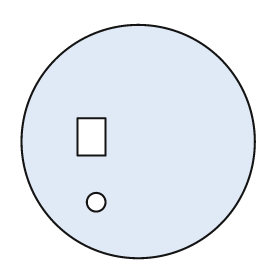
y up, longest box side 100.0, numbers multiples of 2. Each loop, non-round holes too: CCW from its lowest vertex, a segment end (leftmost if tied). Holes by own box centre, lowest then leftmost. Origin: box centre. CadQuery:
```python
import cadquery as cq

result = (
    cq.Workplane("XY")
    .moveTo(0.0, 0.0)
    .circle(50.0)
    .moveTo(-18.0, -26.0)
    .circle(4.0)
    .moveTo(-26.0, -6.0)
    .lineTo(-14.0, -6.0)
    .lineTo(-14.0, 10.0)
    .lineTo(-26.0, 10.0)
    .close()
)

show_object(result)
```